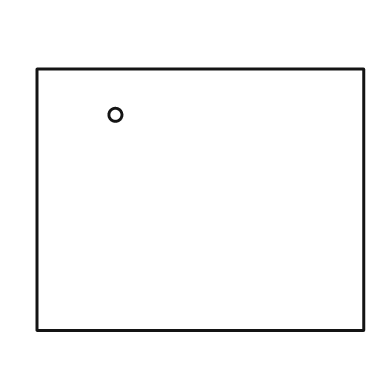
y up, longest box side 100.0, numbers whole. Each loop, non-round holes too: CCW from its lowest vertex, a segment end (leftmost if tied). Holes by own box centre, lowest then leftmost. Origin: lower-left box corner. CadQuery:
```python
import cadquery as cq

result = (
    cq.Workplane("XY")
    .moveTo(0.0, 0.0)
    .lineTo(100.0, 0.0)
    .lineTo(100.0, 80.0)
    .lineTo(0.0, 80.0)
    .close()
    .moveTo(24.0, 66.0)
    .circle(2.0)
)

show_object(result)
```